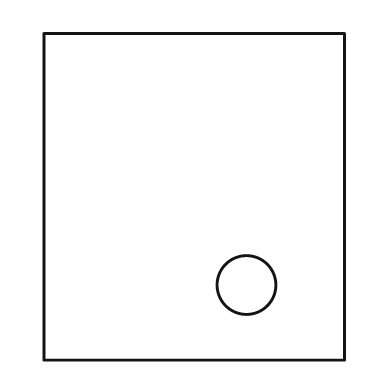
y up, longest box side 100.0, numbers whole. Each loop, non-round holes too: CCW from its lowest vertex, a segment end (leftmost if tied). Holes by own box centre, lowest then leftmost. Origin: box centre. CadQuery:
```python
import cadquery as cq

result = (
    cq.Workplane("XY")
    .moveTo(-46.0, -50.0)
    .lineTo(46.0, -50.0)
    .lineTo(46.0, 50.0)
    .lineTo(-46.0, 50.0)
    .close()
    .moveTo(16.0, -27.0)
    .circle(9.0)
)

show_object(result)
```